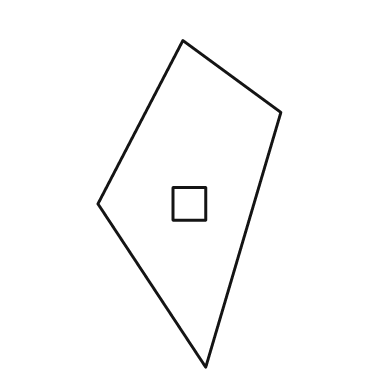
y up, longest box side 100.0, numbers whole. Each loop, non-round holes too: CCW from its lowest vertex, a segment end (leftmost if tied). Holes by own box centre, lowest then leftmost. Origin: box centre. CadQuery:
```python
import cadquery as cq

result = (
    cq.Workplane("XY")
    .moveTo(5.0, -50.0)
    .lineTo(28.0, 28.0)
    .lineTo(-2.0, 50.0)
    .lineTo(-28.0, 0.0)
    .close()
    .moveTo(-5.0, -5.0)
    .lineTo(5.0, -5.0)
    .lineTo(5.0, 5.0)
    .lineTo(-5.0, 5.0)
    .close()
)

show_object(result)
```